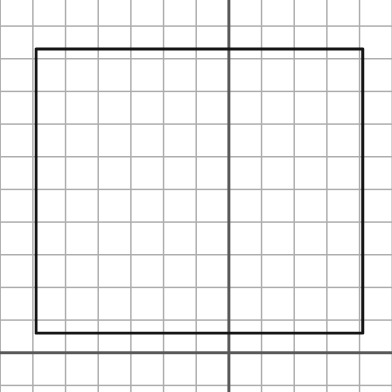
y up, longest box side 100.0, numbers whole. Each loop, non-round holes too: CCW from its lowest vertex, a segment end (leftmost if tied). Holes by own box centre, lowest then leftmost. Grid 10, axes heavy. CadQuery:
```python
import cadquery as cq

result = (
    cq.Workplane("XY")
    .moveTo(-59.0, 6.0)
    .lineTo(41.0, 6.0)
    .lineTo(41.0, 93.0)
    .lineTo(-59.0, 93.0)
    .close()
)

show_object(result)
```